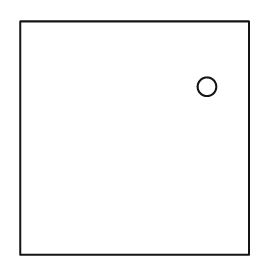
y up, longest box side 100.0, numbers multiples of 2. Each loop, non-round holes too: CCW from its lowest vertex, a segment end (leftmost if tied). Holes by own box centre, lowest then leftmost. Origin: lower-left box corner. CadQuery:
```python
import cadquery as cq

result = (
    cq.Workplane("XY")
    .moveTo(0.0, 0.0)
    .lineTo(98.0, 0.0)
    .lineTo(98.0, 100.0)
    .lineTo(0.0, 100.0)
    .close()
    .moveTo(80.0, 72.0)
    .circle(4.0)
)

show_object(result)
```